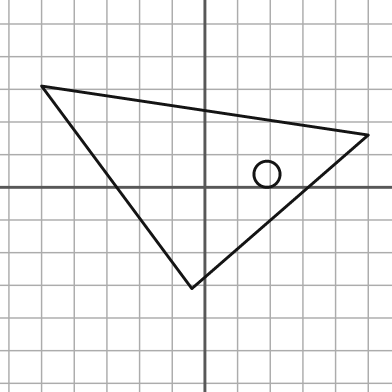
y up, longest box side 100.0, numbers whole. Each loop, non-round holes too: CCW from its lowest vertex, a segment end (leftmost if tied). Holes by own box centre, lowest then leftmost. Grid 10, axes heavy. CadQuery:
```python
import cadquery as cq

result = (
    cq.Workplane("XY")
    .moveTo(-4.0, -31.0)
    .lineTo(50.0, 16.0)
    .lineTo(-50.0, 31.0)
    .close()
    .moveTo(19.0, 4.0)
    .circle(4.0)
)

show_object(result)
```